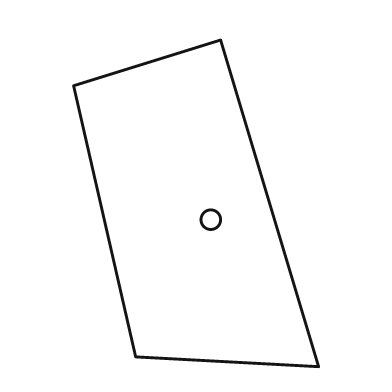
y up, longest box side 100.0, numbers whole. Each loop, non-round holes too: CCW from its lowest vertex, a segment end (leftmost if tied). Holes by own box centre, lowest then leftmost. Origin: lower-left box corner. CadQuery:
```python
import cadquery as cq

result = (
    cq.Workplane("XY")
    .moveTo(75.0, 0.0)
    .lineTo(45.0, 100.0)
    .lineTo(0.0, 86.0)
    .lineTo(19.0, 3.0)
    .close()
    .moveTo(42.0, 45.0)
    .circle(3.0)
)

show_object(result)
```